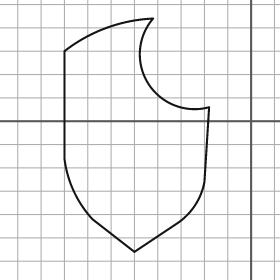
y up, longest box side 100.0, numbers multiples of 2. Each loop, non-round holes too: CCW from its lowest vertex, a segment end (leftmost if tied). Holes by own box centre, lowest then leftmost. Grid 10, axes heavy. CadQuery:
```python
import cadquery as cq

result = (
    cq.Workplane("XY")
    .moveTo(-50.0, -56.0)
    .lineTo(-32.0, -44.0)
    .threePointArc((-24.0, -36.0), (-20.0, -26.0))
    .lineTo(-18.0, 6.0)
    .threePointArc((-44.0, 16.0), (-42.0, 44.0))
    .threePointArc((-62.0, 40.0), (-80.0, 30.0))
    .lineTo(-80.0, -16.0)
    .threePointArc((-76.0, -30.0), (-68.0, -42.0))
    .close()
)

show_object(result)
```